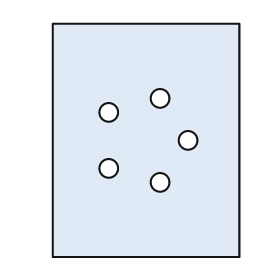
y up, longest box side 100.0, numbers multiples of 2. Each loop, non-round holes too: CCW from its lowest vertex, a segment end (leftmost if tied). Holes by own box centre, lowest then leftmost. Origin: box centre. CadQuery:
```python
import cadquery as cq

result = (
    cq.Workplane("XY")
    .moveTo(-40.0, -50.0)
    .lineTo(40.0, -50.0)
    .lineTo(40.0, 50.0)
    .lineTo(-40.0, 50.0)
    .close()
    .moveTo(6.0, -18.0)
    .circle(4.0)
    .moveTo(-16.0, -12.0)
    .circle(4.0)
    .moveTo(18.0, 0.0)
    .circle(4.0)
    .moveTo(-16.0, 12.0)
    .circle(4.0)
    .moveTo(6.0, 18.0)
    .circle(4.0)
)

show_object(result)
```